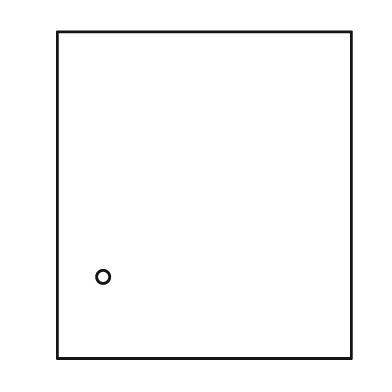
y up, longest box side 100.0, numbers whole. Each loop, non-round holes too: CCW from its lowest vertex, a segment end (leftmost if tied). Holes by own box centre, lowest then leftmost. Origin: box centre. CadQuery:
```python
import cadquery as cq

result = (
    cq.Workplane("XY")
    .moveTo(-45.0, -50.0)
    .lineTo(45.0, -50.0)
    .lineTo(45.0, 50.0)
    .lineTo(-45.0, 50.0)
    .close()
    .moveTo(-31.0, -25.0)
    .circle(2.0)
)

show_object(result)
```